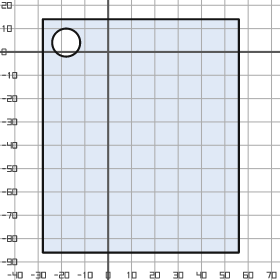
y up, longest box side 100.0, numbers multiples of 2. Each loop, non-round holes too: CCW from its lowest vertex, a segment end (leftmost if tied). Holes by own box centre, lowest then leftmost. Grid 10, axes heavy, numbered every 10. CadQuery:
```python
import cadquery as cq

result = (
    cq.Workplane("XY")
    .moveTo(-28.0, -86.0)
    .lineTo(56.0, -86.0)
    .lineTo(56.0, 14.0)
    .lineTo(-28.0, 14.0)
    .close()
    .moveTo(-18.0, 4.0)
    .circle(6.0)
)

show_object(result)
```